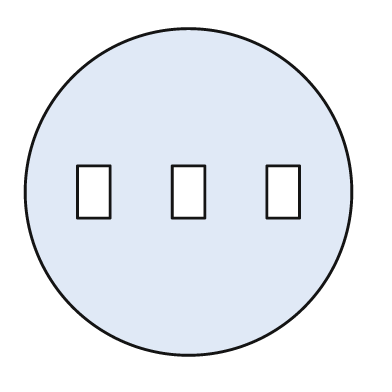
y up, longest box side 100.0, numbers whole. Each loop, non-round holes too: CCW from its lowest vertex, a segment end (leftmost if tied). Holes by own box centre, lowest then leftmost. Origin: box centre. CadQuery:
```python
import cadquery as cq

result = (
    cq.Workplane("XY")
    .moveTo(0.0, 0.0)
    .circle(50.0)
    .moveTo(-34.0, -8.0)
    .lineTo(-24.0, -8.0)
    .lineTo(-24.0, 8.0)
    .lineTo(-34.0, 8.0)
    .close()
    .moveTo(-5.0, -8.0)
    .lineTo(5.0, -8.0)
    .lineTo(5.0, 8.0)
    .lineTo(-5.0, 8.0)
    .close()
    .moveTo(24.0, -8.0)
    .lineTo(34.0, -8.0)
    .lineTo(34.0, 8.0)
    .lineTo(24.0, 8.0)
    .close()
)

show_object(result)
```